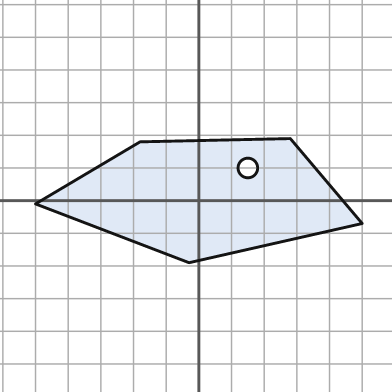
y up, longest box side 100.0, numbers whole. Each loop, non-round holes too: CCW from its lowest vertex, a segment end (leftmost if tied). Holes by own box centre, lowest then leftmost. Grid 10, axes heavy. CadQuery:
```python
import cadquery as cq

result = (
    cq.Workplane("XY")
    .moveTo(-3.0, -19.0)
    .lineTo(50.0, -7.0)
    .lineTo(28.0, 19.0)
    .lineTo(-18.0, 18.0)
    .lineTo(-50.0, -1.0)
    .close()
    .moveTo(15.0, 10.0)
    .circle(3.0)
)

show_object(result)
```